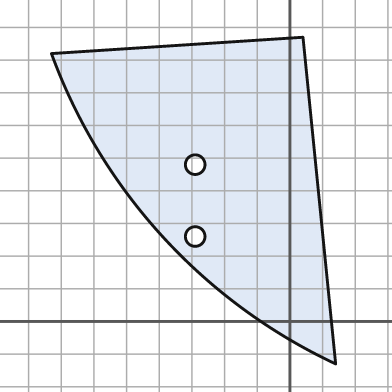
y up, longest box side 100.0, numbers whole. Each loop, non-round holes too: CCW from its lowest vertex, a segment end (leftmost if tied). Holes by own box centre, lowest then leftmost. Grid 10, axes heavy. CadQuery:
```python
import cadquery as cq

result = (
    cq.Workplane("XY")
    .moveTo(14.0, -13.0)
    .lineTo(4.0, 87.0)
    .lineTo(-73.0, 82.0)
    .threePointArc((-39.0, 26.0), (14.0, -13.0))
    .close()
    .moveTo(-29.0, 26.0)
    .circle(3.0)
    .moveTo(-29.0, 48.0)
    .circle(3.0)
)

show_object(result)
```